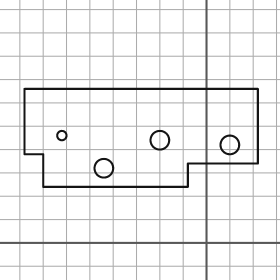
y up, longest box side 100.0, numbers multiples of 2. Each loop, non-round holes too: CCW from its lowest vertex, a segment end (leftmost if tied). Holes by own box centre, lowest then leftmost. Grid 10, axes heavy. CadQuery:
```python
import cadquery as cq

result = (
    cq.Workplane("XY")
    .moveTo(-70.0, 24.0)
    .lineTo(-8.0, 24.0)
    .lineTo(-8.0, 34.0)
    .lineTo(22.0, 34.0)
    .lineTo(22.0, 66.0)
    .lineTo(-78.0, 66.0)
    .lineTo(-78.0, 38.0)
    .lineTo(-70.0, 38.0)
    .close()
    .moveTo(-44.0, 32.0)
    .circle(4.0)
    .moveTo(10.0, 42.0)
    .circle(4.0)
    .moveTo(-20.0, 44.0)
    .circle(4.0)
    .moveTo(-62.0, 46.0)
    .circle(2.0)
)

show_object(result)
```